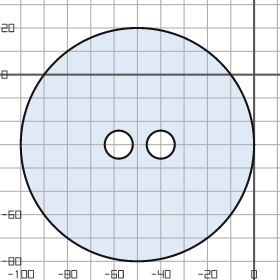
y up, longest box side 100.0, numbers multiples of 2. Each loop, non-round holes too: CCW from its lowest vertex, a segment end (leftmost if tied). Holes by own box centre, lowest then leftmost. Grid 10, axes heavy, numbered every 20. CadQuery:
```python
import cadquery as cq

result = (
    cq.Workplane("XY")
    .moveTo(-50.0, -30.0)
    .circle(50.0)
    .moveTo(-58.0, -30.0)
    .circle(6.0)
    .moveTo(-40.0, -30.0)
    .circle(6.0)
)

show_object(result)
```